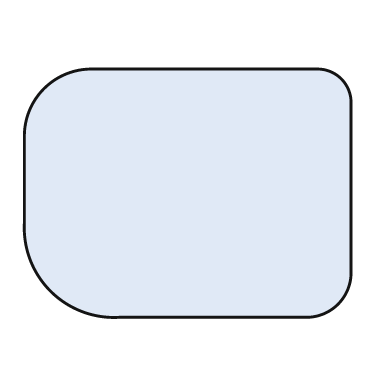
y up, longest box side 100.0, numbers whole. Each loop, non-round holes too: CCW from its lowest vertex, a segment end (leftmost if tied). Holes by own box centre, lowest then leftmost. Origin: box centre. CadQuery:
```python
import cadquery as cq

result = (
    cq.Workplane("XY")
    .moveTo(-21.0, -38.0)
    .lineTo(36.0, -38.0)
    .threePointArc((46.0, -34.0), (50.0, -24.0))
    .lineTo(50.0, 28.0)
    .threePointArc((47.0, 35.0), (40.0, 38.0))
    .lineTo(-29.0, 38.0)
    .threePointArc((-44.0, 32.0), (-50.0, 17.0))
    .lineTo(-50.0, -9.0)
    .threePointArc((-42.0, -30.0), (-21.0, -38.0))
    .close()
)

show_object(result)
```